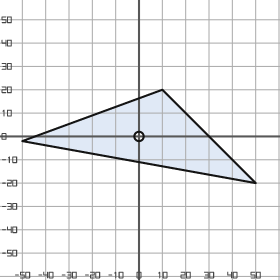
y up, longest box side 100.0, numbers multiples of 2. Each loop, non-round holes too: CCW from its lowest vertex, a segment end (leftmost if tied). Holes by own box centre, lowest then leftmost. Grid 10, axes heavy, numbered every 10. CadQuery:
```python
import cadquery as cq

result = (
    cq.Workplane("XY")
    .moveTo(50.0, -20.0)
    .lineTo(10.0, 20.0)
    .lineTo(-50.0, -2.0)
    .close()
    .moveTo(0.0, 0.0)
    .circle(2.0)
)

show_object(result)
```